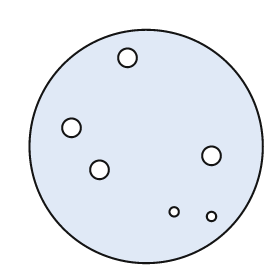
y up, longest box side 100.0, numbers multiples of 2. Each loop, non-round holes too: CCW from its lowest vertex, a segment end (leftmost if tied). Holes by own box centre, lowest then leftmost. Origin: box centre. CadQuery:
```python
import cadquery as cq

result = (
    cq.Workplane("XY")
    .moveTo(0.0, 0.0)
    .circle(50.0)
    .moveTo(28.0, -30.0)
    .circle(2.0)
    .moveTo(12.0, -28.0)
    .circle(2.0)
    .moveTo(-20.0, -10.0)
    .circle(4.0)
    .moveTo(28.0, -4.0)
    .circle(4.0)
    .moveTo(-32.0, 8.0)
    .circle(4.0)
    .moveTo(-8.0, 38.0)
    .circle(4.0)
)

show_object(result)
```